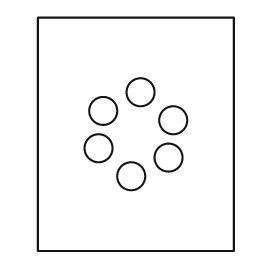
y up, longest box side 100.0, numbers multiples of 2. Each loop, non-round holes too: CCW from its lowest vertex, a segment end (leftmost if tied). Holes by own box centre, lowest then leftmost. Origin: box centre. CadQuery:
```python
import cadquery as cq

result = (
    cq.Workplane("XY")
    .moveTo(-42.0, -50.0)
    .lineTo(42.0, -50.0)
    .lineTo(42.0, 50.0)
    .lineTo(-42.0, 50.0)
    .close()
    .moveTo(-2.0, -18.0)
    .circle(6.0)
    .moveTo(14.0, -10.0)
    .circle(6.0)
    .moveTo(-16.0, -6.0)
    .circle(6.0)
    .moveTo(16.0, 6.0)
    .circle(6.0)
    .moveTo(-14.0, 10.0)
    .circle(6.0)
    .moveTo(2.0, 18.0)
    .circle(6.0)
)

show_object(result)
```